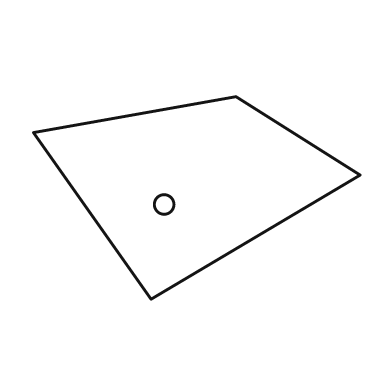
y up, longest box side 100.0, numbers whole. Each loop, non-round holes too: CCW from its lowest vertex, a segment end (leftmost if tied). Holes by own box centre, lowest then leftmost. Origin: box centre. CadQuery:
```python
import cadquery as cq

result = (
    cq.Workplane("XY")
    .moveTo(-14.0, -31.0)
    .lineTo(50.0, 7.0)
    .lineTo(12.0, 31.0)
    .lineTo(-50.0, 20.0)
    .close()
    .moveTo(-10.0, -2.0)
    .circle(3.0)
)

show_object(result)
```